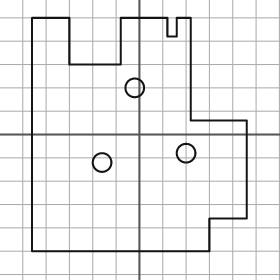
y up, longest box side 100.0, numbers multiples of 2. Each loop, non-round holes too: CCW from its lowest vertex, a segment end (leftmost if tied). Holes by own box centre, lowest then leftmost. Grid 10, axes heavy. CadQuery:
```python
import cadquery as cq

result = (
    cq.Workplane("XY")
    .moveTo(-46.0, -50.0)
    .lineTo(30.0, -50.0)
    .lineTo(30.0, -36.0)
    .lineTo(46.0, -36.0)
    .lineTo(46.0, 6.0)
    .lineTo(22.0, 6.0)
    .lineTo(22.0, 50.0)
    .lineTo(16.0, 50.0)
    .lineTo(16.0, 42.0)
    .lineTo(12.0, 42.0)
    .lineTo(12.0, 50.0)
    .lineTo(-8.0, 50.0)
    .lineTo(-8.0, 30.0)
    .lineTo(-30.0, 30.0)
    .lineTo(-30.0, 50.0)
    .lineTo(-46.0, 50.0)
    .close()
    .moveTo(-16.0, -12.0)
    .circle(4.0)
    .moveTo(20.0, -8.0)
    .circle(4.0)
    .moveTo(-2.0, 20.0)
    .circle(4.0)
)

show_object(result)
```